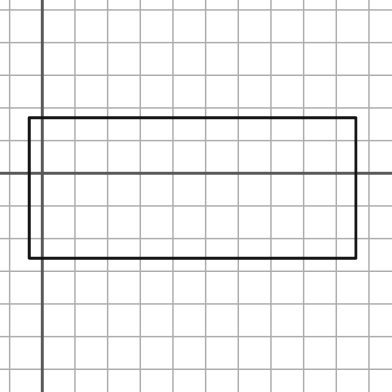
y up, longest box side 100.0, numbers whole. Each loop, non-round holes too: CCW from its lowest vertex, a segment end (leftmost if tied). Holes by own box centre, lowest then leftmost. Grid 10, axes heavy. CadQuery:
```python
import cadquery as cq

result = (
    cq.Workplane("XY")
    .moveTo(-4.0, -26.0)
    .lineTo(96.0, -26.0)
    .lineTo(96.0, 17.0)
    .lineTo(-4.0, 17.0)
    .close()
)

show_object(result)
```